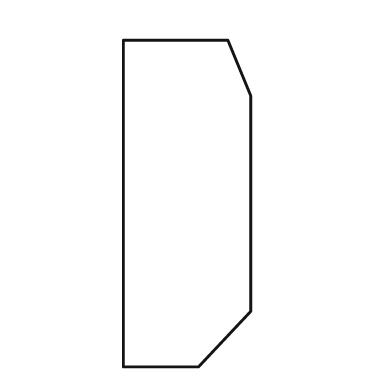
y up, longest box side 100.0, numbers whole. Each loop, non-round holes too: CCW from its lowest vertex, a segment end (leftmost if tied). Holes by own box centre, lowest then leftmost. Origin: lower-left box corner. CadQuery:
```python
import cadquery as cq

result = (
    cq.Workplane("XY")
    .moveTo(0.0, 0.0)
    .lineTo(23.0, 0.0)
    .lineTo(39.0, 17.0)
    .lineTo(39.0, 83.0)
    .lineTo(32.0, 100.0)
    .lineTo(0.0, 100.0)
    .close()
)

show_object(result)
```